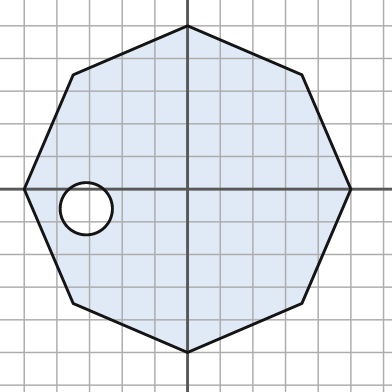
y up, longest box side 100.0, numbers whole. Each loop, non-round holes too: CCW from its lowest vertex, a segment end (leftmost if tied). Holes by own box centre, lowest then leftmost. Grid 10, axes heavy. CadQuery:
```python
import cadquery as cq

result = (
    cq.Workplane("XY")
    .moveTo(0.0, -50.0)
    .lineTo(35.0, -35.0)
    .lineTo(50.0, 0.0)
    .lineTo(35.0, 35.0)
    .lineTo(0.0, 50.0)
    .lineTo(-35.0, 35.0)
    .lineTo(-50.0, 0.0)
    .lineTo(-35.0, -35.0)
    .close()
    .moveTo(-31.0, -6.0)
    .circle(8.0)
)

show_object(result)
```